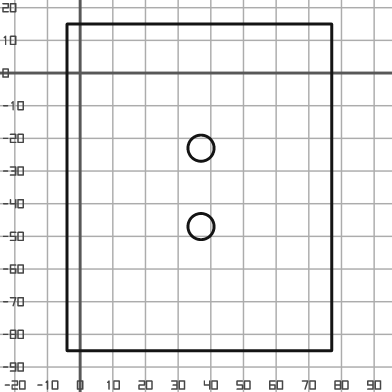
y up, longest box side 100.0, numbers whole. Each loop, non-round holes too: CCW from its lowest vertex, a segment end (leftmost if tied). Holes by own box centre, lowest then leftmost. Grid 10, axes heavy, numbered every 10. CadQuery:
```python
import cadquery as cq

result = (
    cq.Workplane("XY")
    .moveTo(-4.0, -85.0)
    .lineTo(77.0, -85.0)
    .lineTo(77.0, 15.0)
    .lineTo(-4.0, 15.0)
    .close()
    .moveTo(37.0, -47.0)
    .circle(4.0)
    .moveTo(37.0, -23.0)
    .circle(4.0)
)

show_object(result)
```